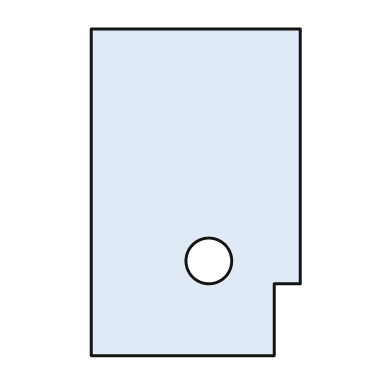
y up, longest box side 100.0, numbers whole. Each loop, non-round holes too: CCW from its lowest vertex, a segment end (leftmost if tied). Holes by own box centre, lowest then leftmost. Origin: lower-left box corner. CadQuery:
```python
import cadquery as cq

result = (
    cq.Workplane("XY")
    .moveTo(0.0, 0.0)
    .lineTo(56.0, 0.0)
    .lineTo(56.0, 22.0)
    .lineTo(64.0, 22.0)
    .lineTo(64.0, 100.0)
    .lineTo(0.0, 100.0)
    .close()
    .moveTo(36.0, 29.0)
    .circle(7.0)
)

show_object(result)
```